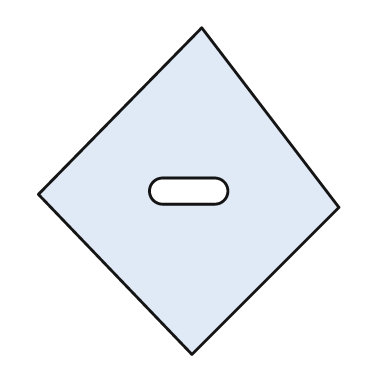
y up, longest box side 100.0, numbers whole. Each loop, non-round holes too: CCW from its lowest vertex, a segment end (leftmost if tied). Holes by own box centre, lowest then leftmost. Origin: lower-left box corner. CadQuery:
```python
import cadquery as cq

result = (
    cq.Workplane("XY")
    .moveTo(47.0, 0.0)
    .lineTo(92.0, 45.0)
    .lineTo(50.0, 100.0)
    .lineTo(0.0, 49.0)
    .close()
    .moveTo(38.0, 46.0)
    .lineTo(54.0, 46.0)
    .threePointArc((58.0, 50.0), (54.0, 54.0))
    .lineTo(38.0, 54.0)
    .threePointArc((34.0, 50.0), (38.0, 46.0))
    .close()
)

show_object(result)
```